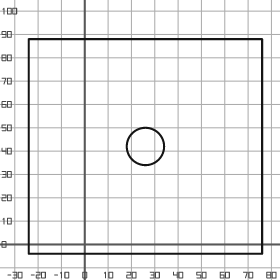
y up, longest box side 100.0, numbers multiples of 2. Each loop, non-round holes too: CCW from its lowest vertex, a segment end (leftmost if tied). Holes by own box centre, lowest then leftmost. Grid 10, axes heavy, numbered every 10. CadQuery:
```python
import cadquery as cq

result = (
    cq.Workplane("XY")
    .moveTo(-24.0, -4.0)
    .lineTo(76.0, -4.0)
    .lineTo(76.0, 88.0)
    .lineTo(-24.0, 88.0)
    .close()
    .moveTo(26.0, 42.0)
    .circle(8.0)
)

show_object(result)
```